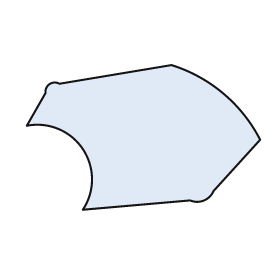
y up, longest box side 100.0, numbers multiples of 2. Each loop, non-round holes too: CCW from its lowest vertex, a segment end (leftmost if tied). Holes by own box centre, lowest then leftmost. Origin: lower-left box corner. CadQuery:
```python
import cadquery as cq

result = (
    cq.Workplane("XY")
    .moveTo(24.0, 0.0)
    .lineTo(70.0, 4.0)
    .threePointArc((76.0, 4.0), (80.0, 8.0))
    .lineTo(100.0, 30.0)
    .threePointArc((84.0, 50.0), (62.0, 62.0))
    .lineTo(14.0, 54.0)
    .threePointArc((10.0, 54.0), (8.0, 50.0))
    .lineTo(0.0, 36.0)
    .threePointArc((24.0, 26.0), (24.0, 0.0))
    .close()
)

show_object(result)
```